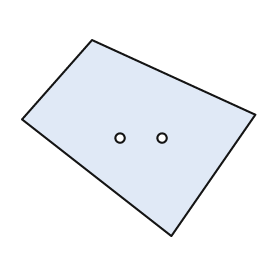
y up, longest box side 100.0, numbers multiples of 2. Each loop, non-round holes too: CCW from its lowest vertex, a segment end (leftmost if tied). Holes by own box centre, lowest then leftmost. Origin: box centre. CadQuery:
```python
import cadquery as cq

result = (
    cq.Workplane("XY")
    .moveTo(14.0, -42.0)
    .lineTo(50.0, 10.0)
    .lineTo(-20.0, 42.0)
    .lineTo(-50.0, 8.0)
    .close()
    .moveTo(-8.0, 0.0)
    .circle(2.0)
    .moveTo(10.0, 0.0)
    .circle(2.0)
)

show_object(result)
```